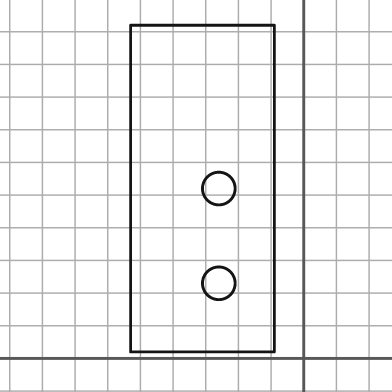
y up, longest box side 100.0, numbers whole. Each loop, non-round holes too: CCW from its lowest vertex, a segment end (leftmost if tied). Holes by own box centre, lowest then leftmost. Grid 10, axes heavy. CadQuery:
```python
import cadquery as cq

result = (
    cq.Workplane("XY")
    .moveTo(-53.0, 2.0)
    .lineTo(-9.0, 2.0)
    .lineTo(-9.0, 102.0)
    .lineTo(-53.0, 102.0)
    .close()
    .moveTo(-26.0, 23.0)
    .circle(5.0)
    .moveTo(-26.0, 52.0)
    .circle(5.0)
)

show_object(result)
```